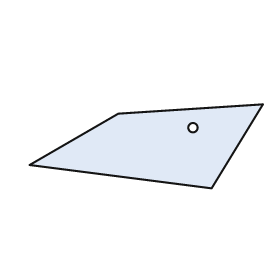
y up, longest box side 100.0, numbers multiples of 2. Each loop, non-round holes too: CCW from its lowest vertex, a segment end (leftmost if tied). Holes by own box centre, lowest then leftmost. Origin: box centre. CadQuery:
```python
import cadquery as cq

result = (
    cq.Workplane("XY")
    .moveTo(28.0, -18.0)
    .lineTo(50.0, 18.0)
    .lineTo(-12.0, 14.0)
    .lineTo(-50.0, -8.0)
    .close()
    .moveTo(20.0, 8.0)
    .circle(2.0)
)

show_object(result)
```